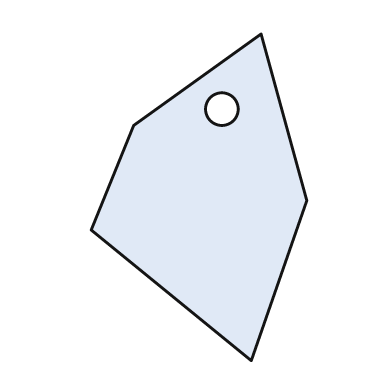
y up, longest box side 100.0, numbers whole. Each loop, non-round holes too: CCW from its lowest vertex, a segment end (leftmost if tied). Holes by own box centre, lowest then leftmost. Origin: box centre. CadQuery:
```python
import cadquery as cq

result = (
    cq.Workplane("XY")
    .moveTo(16.0, -50.0)
    .lineTo(33.0, -1.0)
    .lineTo(19.0, 50.0)
    .lineTo(-20.0, 22.0)
    .lineTo(-33.0, -10.0)
    .close()
    .moveTo(7.0, 27.0)
    .circle(5.0)
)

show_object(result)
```